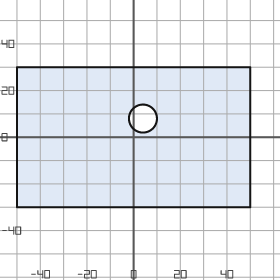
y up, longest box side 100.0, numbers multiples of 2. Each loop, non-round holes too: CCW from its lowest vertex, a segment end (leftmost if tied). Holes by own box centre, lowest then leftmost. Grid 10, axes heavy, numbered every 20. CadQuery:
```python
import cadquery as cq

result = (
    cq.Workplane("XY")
    .moveTo(-50.0, -30.0)
    .lineTo(50.0, -30.0)
    .lineTo(50.0, 30.0)
    .lineTo(-50.0, 30.0)
    .close()
    .moveTo(4.0, 8.0)
    .circle(6.0)
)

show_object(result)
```